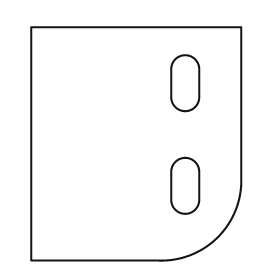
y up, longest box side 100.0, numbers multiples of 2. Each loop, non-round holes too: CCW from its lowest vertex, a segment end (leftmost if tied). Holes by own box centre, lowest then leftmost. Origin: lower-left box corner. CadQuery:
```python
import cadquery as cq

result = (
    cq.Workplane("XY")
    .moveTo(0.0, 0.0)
    .lineTo(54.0, 0.0)
    .threePointArc((80.0, 10.0), (90.0, 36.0))
    .lineTo(90.0, 100.0)
    .lineTo(0.0, 100.0)
    .close()
    .moveTo(60.0, 26.0)
    .threePointArc((66.0, 20.0), (72.0, 26.0))
    .lineTo(72.0, 38.0)
    .threePointArc((66.0, 44.0), (60.0, 38.0))
    .close()
    .moveTo(60.0, 70.0)
    .threePointArc((66.0, 64.0), (72.0, 70.0))
    .lineTo(72.0, 82.0)
    .threePointArc((66.0, 88.0), (60.0, 82.0))
    .close()
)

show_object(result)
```